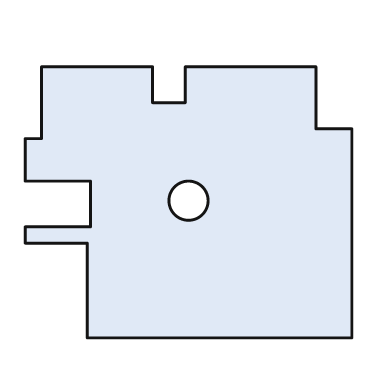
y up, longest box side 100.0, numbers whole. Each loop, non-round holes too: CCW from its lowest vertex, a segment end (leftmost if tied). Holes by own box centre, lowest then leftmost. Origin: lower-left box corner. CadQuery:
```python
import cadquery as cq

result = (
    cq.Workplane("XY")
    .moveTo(19.0, 0.0)
    .lineTo(100.0, 0.0)
    .lineTo(100.0, 64.0)
    .lineTo(89.0, 64.0)
    .lineTo(89.0, 83.0)
    .lineTo(49.0, 83.0)
    .lineTo(49.0, 72.0)
    .lineTo(39.0, 72.0)
    .lineTo(39.0, 83.0)
    .lineTo(5.0, 83.0)
    .lineTo(5.0, 61.0)
    .lineTo(0.0, 61.0)
    .lineTo(0.0, 48.0)
    .lineTo(20.0, 48.0)
    .lineTo(20.0, 34.0)
    .lineTo(0.0, 34.0)
    .lineTo(0.0, 29.0)
    .lineTo(19.0, 29.0)
    .close()
    .moveTo(50.0, 42.0)
    .circle(6.0)
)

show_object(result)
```